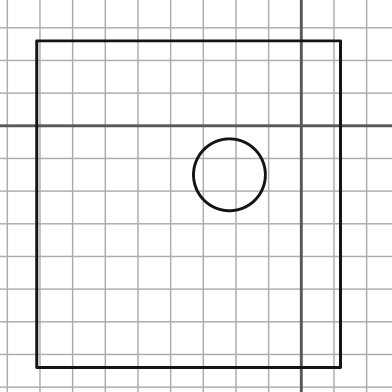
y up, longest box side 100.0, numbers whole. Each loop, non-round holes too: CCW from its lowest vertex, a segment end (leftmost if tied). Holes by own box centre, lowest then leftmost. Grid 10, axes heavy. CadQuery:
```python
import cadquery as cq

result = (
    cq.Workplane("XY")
    .moveTo(-81.0, -74.0)
    .lineTo(12.0, -74.0)
    .lineTo(12.0, 26.0)
    .lineTo(-81.0, 26.0)
    .close()
    .moveTo(-22.0, -15.0)
    .circle(11.0)
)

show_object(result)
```